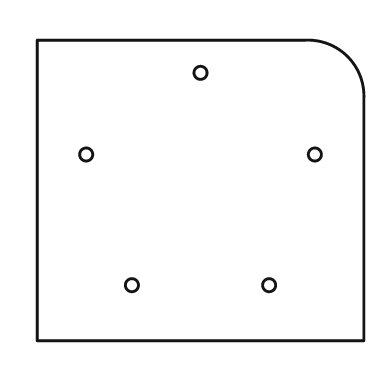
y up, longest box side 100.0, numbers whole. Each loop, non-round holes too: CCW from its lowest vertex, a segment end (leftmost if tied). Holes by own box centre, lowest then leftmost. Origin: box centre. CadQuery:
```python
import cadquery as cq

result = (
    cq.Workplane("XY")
    .moveTo(-50.0, -46.0)
    .lineTo(50.0, -46.0)
    .lineTo(50.0, 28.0)
    .threePointArc((45.0, 41.0), (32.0, 46.0))
    .lineTo(-50.0, 46.0)
    .close()
    .moveTo(-21.0, -29.0)
    .circle(2.0)
    .moveTo(21.0, -29.0)
    .circle(2.0)
    .moveTo(-35.0, 11.0)
    .circle(2.0)
    .moveTo(35.0, 11.0)
    .circle(2.0)
    .moveTo(0.0, 36.0)
    .circle(2.0)
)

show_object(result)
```